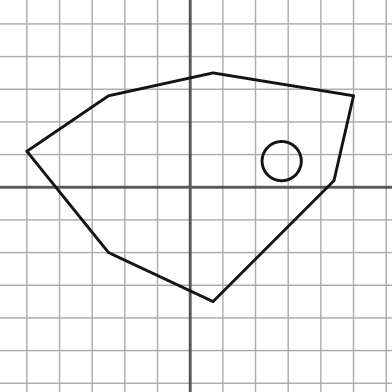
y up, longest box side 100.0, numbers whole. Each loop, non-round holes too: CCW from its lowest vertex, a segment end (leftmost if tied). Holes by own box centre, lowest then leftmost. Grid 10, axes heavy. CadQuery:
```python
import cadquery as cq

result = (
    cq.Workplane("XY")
    .moveTo(7.0, -35.0)
    .lineTo(44.0, 2.0)
    .lineTo(50.0, 28.0)
    .lineTo(7.0, 35.0)
    .lineTo(-25.0, 28.0)
    .lineTo(-50.0, 11.0)
    .lineTo(-25.0, -20.0)
    .close()
    .moveTo(28.0, 8.0)
    .circle(6.0)
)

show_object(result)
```